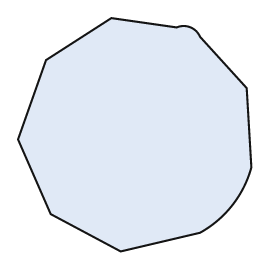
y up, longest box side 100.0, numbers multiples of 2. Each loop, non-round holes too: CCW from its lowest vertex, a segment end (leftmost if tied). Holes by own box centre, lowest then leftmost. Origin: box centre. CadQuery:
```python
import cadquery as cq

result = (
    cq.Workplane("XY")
    .moveTo(-6.0, -50.0)
    .lineTo(28.0, -42.0)
    .threePointArc((42.0, -30.0), (50.0, -14.0))
    .lineTo(48.0, 20.0)
    .lineTo(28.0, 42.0)
    .threePointArc((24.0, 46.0), (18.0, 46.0))
    .lineTo(-10.0, 50.0)
    .lineTo(-38.0, 32.0)
    .lineTo(-50.0, -2.0)
    .lineTo(-36.0, -34.0)
    .close()
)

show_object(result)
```